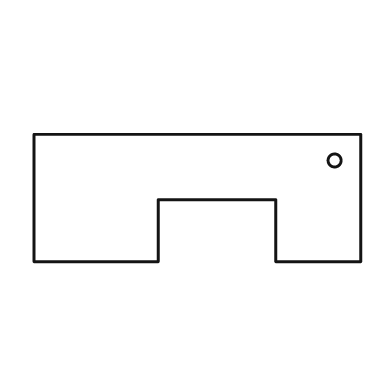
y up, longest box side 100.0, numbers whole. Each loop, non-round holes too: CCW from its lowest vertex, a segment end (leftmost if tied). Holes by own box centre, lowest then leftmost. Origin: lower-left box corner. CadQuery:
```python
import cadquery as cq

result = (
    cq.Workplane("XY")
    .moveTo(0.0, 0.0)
    .lineTo(38.0, 0.0)
    .lineTo(38.0, 19.0)
    .lineTo(74.0, 19.0)
    .lineTo(74.0, 0.0)
    .lineTo(100.0, 0.0)
    .lineTo(100.0, 39.0)
    .lineTo(0.0, 39.0)
    .close()
    .moveTo(92.0, 31.0)
    .circle(2.0)
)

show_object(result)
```